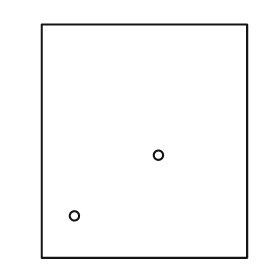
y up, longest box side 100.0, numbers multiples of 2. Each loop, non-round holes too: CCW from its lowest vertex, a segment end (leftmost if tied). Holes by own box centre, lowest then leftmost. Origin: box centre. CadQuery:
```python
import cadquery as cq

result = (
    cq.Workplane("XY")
    .moveTo(-44.0, -50.0)
    .lineTo(44.0, -50.0)
    .lineTo(44.0, 50.0)
    .lineTo(-44.0, 50.0)
    .close()
    .moveTo(-30.0, -32.0)
    .circle(2.0)
    .moveTo(6.0, -6.0)
    .circle(2.0)
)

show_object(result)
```